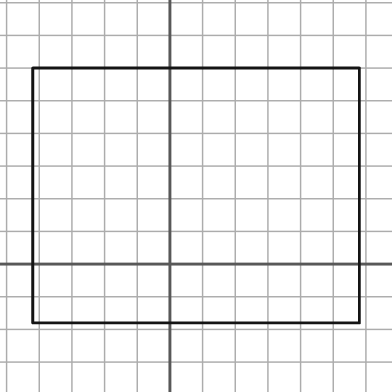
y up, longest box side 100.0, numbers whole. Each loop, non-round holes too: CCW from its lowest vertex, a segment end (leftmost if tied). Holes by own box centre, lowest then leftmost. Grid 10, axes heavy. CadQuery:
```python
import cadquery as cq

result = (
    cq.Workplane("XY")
    .moveTo(-42.0, -18.0)
    .lineTo(58.0, -18.0)
    .lineTo(58.0, 60.0)
    .lineTo(-42.0, 60.0)
    .close()
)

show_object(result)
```